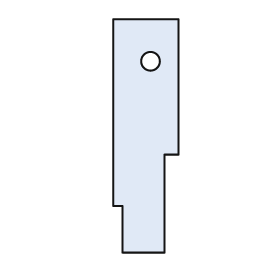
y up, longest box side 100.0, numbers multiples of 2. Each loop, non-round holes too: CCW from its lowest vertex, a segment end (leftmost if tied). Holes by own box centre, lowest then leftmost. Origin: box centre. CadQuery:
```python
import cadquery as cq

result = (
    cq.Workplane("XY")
    .moveTo(-10.0, -50.0)
    .lineTo(8.0, -50.0)
    .lineTo(8.0, -8.0)
    .lineTo(14.0, -8.0)
    .lineTo(14.0, 50.0)
    .lineTo(-14.0, 50.0)
    .lineTo(-14.0, -30.0)
    .lineTo(-10.0, -30.0)
    .close()
    .moveTo(2.0, 32.0)
    .circle(4.0)
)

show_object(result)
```